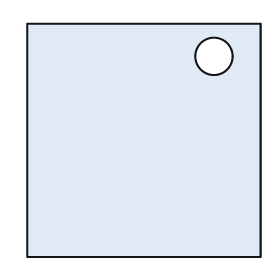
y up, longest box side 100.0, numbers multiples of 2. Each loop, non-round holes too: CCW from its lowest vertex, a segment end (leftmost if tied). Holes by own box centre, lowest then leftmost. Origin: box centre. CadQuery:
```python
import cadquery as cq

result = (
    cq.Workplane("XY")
    .moveTo(-50.0, -50.0)
    .lineTo(50.0, -50.0)
    .lineTo(50.0, 50.0)
    .lineTo(-50.0, 50.0)
    .close()
    .moveTo(30.0, 36.0)
    .circle(8.0)
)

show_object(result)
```